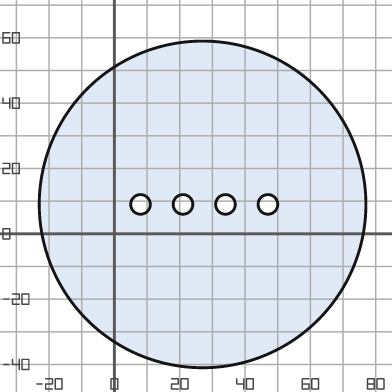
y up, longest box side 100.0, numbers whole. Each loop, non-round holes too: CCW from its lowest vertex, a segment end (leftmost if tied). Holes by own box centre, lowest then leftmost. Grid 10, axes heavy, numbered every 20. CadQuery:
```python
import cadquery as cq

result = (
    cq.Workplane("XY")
    .moveTo(27.0, 9.0)
    .circle(50.0)
    .moveTo(8.0, 9.0)
    .circle(3.0)
    .moveTo(21.0, 9.0)
    .circle(3.0)
    .moveTo(34.0, 9.0)
    .circle(3.0)
    .moveTo(47.0, 9.0)
    .circle(3.0)
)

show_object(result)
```